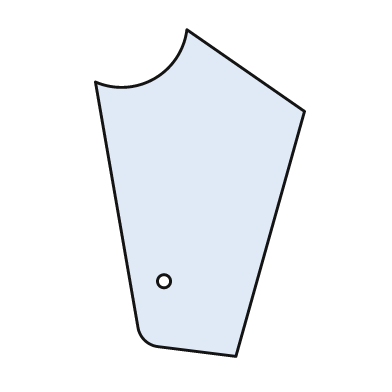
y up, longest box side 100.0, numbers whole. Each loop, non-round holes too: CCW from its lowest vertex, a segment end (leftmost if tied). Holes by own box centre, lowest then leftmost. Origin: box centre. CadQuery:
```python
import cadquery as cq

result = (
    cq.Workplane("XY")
    .moveTo(11.0, -50.0)
    .lineTo(32.0, 25.0)
    .lineTo(-4.0, 50.0)
    .threePointArc((-14.0, 35.0), (-32.0, 34.0))
    .lineTo(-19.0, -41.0)
    .threePointArc((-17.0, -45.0), (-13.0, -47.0))
    .close()
    .moveTo(-11.0, -27.0)
    .circle(2.0)
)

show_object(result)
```